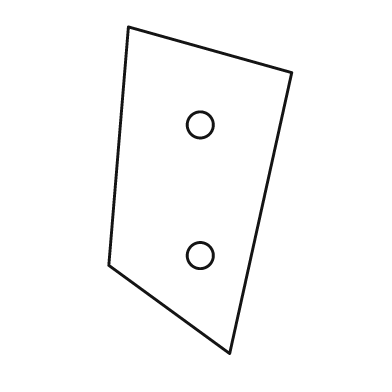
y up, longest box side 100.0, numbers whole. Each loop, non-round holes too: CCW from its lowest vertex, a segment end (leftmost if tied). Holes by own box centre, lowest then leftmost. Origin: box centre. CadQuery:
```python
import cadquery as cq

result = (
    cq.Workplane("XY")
    .moveTo(9.0, -50.0)
    .lineTo(28.0, 36.0)
    .lineTo(-22.0, 50.0)
    .lineTo(-28.0, -23.0)
    .close()
    .moveTo(0.0, -20.0)
    .circle(4.0)
    .moveTo(0.0, 20.0)
    .circle(4.0)
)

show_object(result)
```